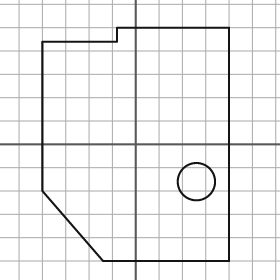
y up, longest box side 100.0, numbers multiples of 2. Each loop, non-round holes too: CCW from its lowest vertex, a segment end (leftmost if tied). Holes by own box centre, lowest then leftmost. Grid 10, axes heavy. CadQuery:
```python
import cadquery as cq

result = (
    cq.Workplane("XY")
    .moveTo(-14.0, -50.0)
    .lineTo(40.0, -50.0)
    .lineTo(40.0, 50.0)
    .lineTo(-8.0, 50.0)
    .lineTo(-8.0, 44.0)
    .lineTo(-40.0, 44.0)
    .lineTo(-40.0, -20.0)
    .close()
    .moveTo(26.0, -16.0)
    .circle(8.0)
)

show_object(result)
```